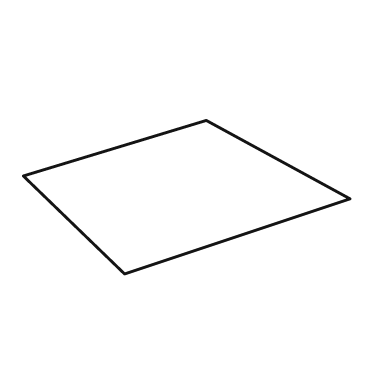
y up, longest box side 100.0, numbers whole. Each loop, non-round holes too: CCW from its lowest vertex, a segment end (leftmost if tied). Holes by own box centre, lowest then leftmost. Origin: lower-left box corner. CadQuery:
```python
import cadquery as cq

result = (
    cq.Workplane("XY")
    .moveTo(31.0, 0.0)
    .lineTo(100.0, 23.0)
    .lineTo(56.0, 47.0)
    .lineTo(0.0, 30.0)
    .close()
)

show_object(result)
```